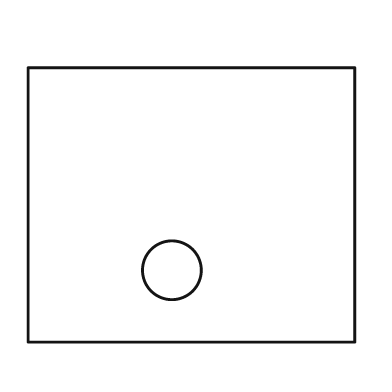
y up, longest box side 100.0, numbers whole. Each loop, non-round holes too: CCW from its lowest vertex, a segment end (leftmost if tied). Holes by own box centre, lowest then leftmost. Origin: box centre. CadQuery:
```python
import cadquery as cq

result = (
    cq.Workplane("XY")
    .moveTo(-50.0, -42.0)
    .lineTo(50.0, -42.0)
    .lineTo(50.0, 42.0)
    .lineTo(-50.0, 42.0)
    .close()
    .moveTo(-6.0, -20.0)
    .circle(9.0)
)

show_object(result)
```